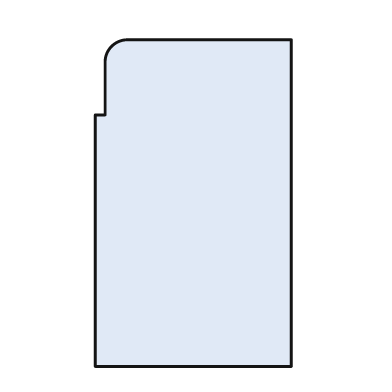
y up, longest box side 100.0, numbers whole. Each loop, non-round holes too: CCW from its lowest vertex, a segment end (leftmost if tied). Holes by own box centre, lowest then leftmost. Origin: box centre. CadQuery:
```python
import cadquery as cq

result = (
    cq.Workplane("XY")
    .moveTo(-30.0, -50.0)
    .lineTo(30.0, -50.0)
    .lineTo(30.0, 50.0)
    .lineTo(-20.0, 50.0)
    .threePointArc((-25.0, 48.0), (-27.0, 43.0))
    .lineTo(-27.0, 27.0)
    .lineTo(-30.0, 27.0)
    .close()
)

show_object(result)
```